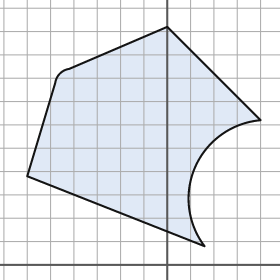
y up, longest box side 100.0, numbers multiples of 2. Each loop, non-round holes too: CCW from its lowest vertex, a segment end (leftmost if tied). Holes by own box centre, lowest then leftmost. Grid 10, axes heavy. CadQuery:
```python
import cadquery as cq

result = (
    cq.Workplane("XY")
    .moveTo(16.0, 8.0)
    .threePointArc((12.0, 42.0), (40.0, 62.0))
    .lineTo(0.0, 102.0)
    .lineTo(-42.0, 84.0)
    .threePointArc((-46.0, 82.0), (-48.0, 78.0))
    .lineTo(-60.0, 38.0)
    .close()
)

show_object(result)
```